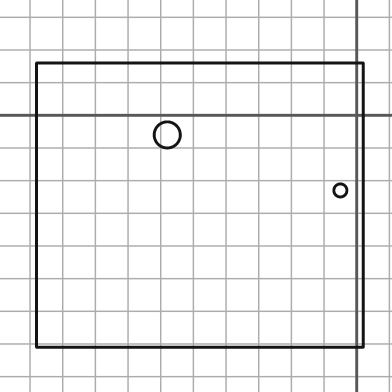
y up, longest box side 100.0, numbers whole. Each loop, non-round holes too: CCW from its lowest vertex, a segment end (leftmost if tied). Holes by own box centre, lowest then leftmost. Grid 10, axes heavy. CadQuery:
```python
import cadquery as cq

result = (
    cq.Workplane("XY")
    .moveTo(-98.0, -71.0)
    .lineTo(2.0, -71.0)
    .lineTo(2.0, 16.0)
    .lineTo(-98.0, 16.0)
    .close()
    .moveTo(-5.0, -23.0)
    .circle(2.0)
    .moveTo(-58.0, -6.0)
    .circle(4.0)
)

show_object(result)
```